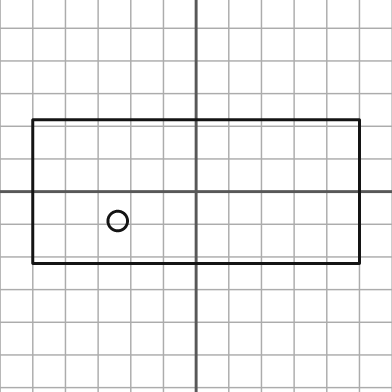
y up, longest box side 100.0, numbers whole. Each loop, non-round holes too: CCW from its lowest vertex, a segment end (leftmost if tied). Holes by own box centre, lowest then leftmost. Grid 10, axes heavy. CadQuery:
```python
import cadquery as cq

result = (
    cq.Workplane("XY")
    .moveTo(-50.0, -22.0)
    .lineTo(50.0, -22.0)
    .lineTo(50.0, 22.0)
    .lineTo(-50.0, 22.0)
    .close()
    .moveTo(-24.0, -9.0)
    .circle(3.0)
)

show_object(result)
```